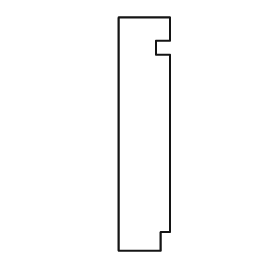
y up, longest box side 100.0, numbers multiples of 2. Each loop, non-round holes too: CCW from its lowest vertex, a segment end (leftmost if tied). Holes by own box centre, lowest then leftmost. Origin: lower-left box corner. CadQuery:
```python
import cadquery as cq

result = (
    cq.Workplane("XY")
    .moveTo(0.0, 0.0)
    .lineTo(18.0, 0.0)
    .lineTo(18.0, 8.0)
    .lineTo(22.0, 8.0)
    .lineTo(22.0, 84.0)
    .lineTo(16.0, 84.0)
    .lineTo(16.0, 90.0)
    .lineTo(22.0, 90.0)
    .lineTo(22.0, 100.0)
    .lineTo(0.0, 100.0)
    .close()
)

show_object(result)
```